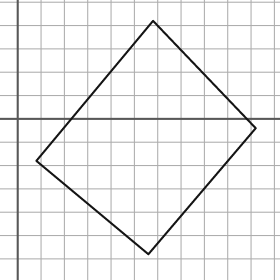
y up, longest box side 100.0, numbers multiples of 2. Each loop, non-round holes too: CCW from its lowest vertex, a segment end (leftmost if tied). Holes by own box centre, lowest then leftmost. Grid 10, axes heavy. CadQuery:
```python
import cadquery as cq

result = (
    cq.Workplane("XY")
    .moveTo(56.0, -58.0)
    .lineTo(102.0, -4.0)
    .lineTo(58.0, 42.0)
    .lineTo(8.0, -18.0)
    .close()
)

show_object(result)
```